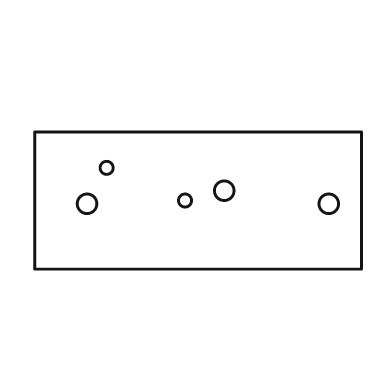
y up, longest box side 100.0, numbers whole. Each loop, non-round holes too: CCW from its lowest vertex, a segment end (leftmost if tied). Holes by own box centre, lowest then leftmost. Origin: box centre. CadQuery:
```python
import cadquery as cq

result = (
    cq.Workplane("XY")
    .moveTo(-50.0, -21.0)
    .lineTo(50.0, -21.0)
    .lineTo(50.0, 21.0)
    .lineTo(-50.0, 21.0)
    .close()
    .moveTo(-34.0, -1.0)
    .circle(3.0)
    .moveTo(40.0, -1.0)
    .circle(3.0)
    .moveTo(-4.0, 0.0)
    .circle(2.0)
    .moveTo(8.0, 3.0)
    .circle(3.0)
    .moveTo(-28.0, 10.0)
    .circle(2.0)
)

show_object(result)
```